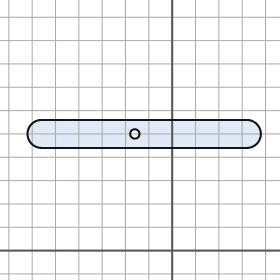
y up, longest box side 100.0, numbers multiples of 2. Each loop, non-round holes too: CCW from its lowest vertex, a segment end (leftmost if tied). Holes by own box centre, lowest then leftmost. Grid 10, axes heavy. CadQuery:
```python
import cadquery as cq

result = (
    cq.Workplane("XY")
    .moveTo(-56.0, 44.0)
    .lineTo(32.0, 44.0)
    .threePointArc((38.0, 50.0), (32.0, 56.0))
    .lineTo(-56.0, 56.0)
    .threePointArc((-62.0, 50.0), (-56.0, 44.0))
    .close()
    .moveTo(-16.0, 50.0)
    .circle(2.0)
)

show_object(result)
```